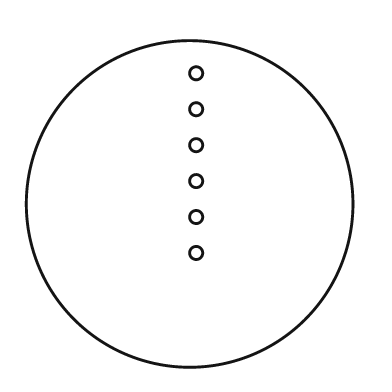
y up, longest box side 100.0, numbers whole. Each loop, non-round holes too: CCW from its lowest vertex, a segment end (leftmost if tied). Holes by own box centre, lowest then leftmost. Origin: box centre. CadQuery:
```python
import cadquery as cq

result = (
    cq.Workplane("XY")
    .moveTo(0.0, 0.0)
    .circle(50.0)
    .moveTo(2.0, -15.0)
    .circle(2.0)
    .moveTo(2.0, -4.0)
    .circle(2.0)
    .moveTo(2.0, 7.0)
    .circle(2.0)
    .moveTo(2.0, 18.0)
    .circle(2.0)
    .moveTo(2.0, 29.0)
    .circle(2.0)
    .moveTo(2.0, 40.0)
    .circle(2.0)
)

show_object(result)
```